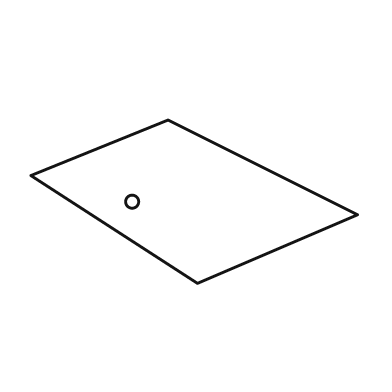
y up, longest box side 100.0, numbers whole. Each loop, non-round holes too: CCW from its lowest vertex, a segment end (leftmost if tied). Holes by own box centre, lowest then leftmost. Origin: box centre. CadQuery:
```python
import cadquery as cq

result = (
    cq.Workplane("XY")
    .moveTo(1.0, -25.0)
    .lineTo(50.0, -4.0)
    .lineTo(-8.0, 25.0)
    .lineTo(-50.0, 8.0)
    .close()
    .moveTo(-19.0, 0.0)
    .circle(2.0)
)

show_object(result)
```